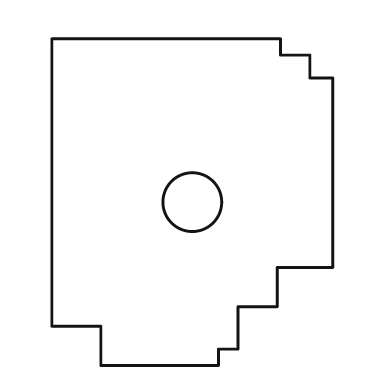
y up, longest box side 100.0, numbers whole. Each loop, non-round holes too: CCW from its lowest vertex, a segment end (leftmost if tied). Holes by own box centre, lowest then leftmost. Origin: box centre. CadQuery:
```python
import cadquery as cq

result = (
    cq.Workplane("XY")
    .moveTo(-28.0, -50.0)
    .lineTo(8.0, -50.0)
    .lineTo(8.0, -45.0)
    .lineTo(14.0, -45.0)
    .lineTo(14.0, -32.0)
    .lineTo(26.0, -32.0)
    .lineTo(26.0, -20.0)
    .lineTo(43.0, -20.0)
    .lineTo(43.0, 38.0)
    .lineTo(36.0, 38.0)
    .lineTo(36.0, 45.0)
    .lineTo(27.0, 45.0)
    .lineTo(27.0, 50.0)
    .lineTo(-43.0, 50.0)
    .lineTo(-43.0, -38.0)
    .lineTo(-28.0, -38.0)
    .close()
    .moveTo(0.0, 0.0)
    .circle(9.0)
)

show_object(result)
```